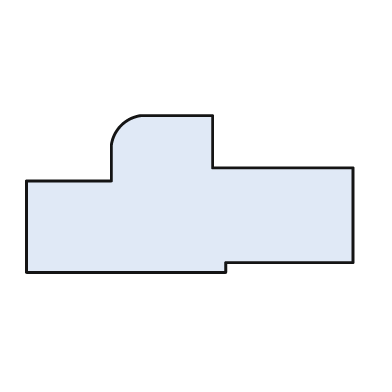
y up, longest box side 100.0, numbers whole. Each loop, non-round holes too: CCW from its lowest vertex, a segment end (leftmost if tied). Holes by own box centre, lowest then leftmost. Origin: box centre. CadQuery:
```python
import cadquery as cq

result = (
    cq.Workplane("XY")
    .moveTo(-50.0, -24.0)
    .lineTo(11.0, -24.0)
    .lineTo(11.0, -21.0)
    .lineTo(50.0, -21.0)
    .lineTo(50.0, 8.0)
    .lineTo(7.0, 8.0)
    .lineTo(7.0, 24.0)
    .lineTo(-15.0, 24.0)
    .threePointArc((-21.0, 21.0), (-24.0, 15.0))
    .lineTo(-24.0, 4.0)
    .lineTo(-50.0, 4.0)
    .close()
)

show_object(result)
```